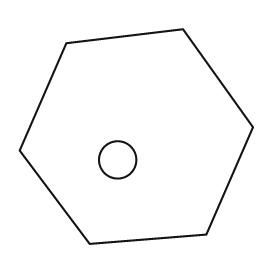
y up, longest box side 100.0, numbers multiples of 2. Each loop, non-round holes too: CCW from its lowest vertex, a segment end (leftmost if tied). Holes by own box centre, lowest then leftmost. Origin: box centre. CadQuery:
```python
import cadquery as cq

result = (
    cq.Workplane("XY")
    .moveTo(-20.0, -46.0)
    .lineTo(30.0, -42.0)
    .lineTo(50.0, 4.0)
    .lineTo(20.0, 46.0)
    .lineTo(-30.0, 40.0)
    .lineTo(-50.0, -6.0)
    .close()
    .moveTo(-8.0, -10.0)
    .circle(8.0)
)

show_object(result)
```